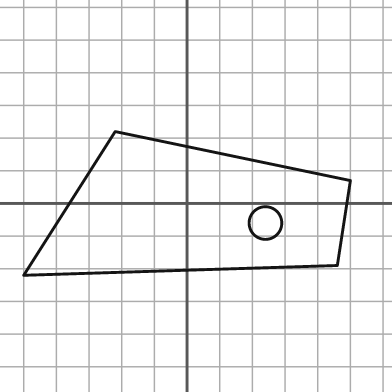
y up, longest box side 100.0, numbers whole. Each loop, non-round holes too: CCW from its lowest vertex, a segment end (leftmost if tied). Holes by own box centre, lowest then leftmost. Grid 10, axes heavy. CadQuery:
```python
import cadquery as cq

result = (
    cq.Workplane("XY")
    .moveTo(-50.0, -22.0)
    .lineTo(46.0, -19.0)
    .lineTo(50.0, 7.0)
    .lineTo(-22.0, 22.0)
    .close()
    .moveTo(24.0, -6.0)
    .circle(5.0)
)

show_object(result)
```